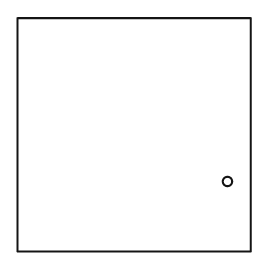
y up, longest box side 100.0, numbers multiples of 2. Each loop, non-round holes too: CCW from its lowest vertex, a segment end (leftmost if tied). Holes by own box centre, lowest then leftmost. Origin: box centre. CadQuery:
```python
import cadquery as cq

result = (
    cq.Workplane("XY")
    .moveTo(-50.0, -50.0)
    .lineTo(50.0, -50.0)
    .lineTo(50.0, 50.0)
    .lineTo(-50.0, 50.0)
    .close()
    .moveTo(40.0, -20.0)
    .circle(2.0)
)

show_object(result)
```